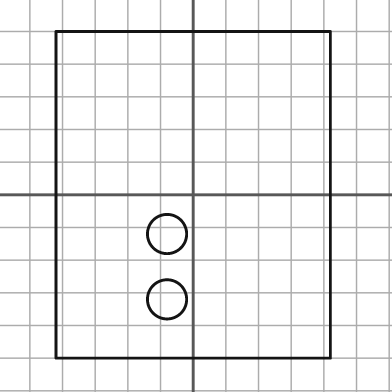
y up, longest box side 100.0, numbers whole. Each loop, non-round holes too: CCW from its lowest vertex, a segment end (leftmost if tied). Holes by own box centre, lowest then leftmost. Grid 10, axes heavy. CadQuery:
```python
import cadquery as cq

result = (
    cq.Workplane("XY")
    .moveTo(-42.0, -50.0)
    .lineTo(42.0, -50.0)
    .lineTo(42.0, 50.0)
    .lineTo(-42.0, 50.0)
    .close()
    .moveTo(-8.0, -32.0)
    .circle(6.0)
    .moveTo(-8.0, -12.0)
    .circle(6.0)
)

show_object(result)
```